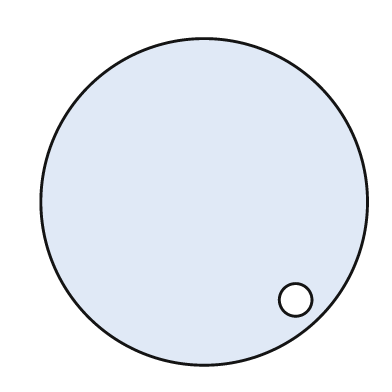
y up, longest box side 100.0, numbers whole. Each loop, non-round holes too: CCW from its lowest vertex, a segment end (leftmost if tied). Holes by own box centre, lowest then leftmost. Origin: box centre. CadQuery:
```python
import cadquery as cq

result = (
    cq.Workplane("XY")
    .moveTo(0.0, 0.0)
    .circle(50.0)
    .moveTo(28.0, -30.0)
    .circle(5.0)
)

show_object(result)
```